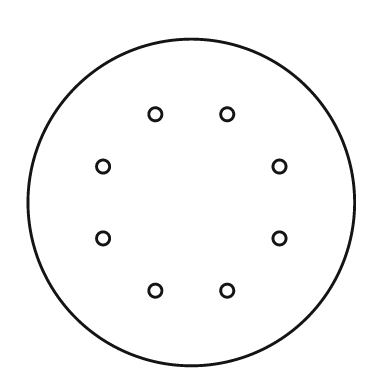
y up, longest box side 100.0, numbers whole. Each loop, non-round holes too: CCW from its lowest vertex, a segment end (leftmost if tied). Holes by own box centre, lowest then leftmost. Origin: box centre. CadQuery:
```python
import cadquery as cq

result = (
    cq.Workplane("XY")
    .moveTo(0.0, 0.0)
    .circle(50.0)
    .moveTo(-11.0, -27.0)
    .circle(2.0)
    .moveTo(11.0, -27.0)
    .circle(2.0)
    .moveTo(-27.0, -11.0)
    .circle(2.0)
    .moveTo(27.0, -11.0)
    .circle(2.0)
    .moveTo(-27.0, 11.0)
    .circle(2.0)
    .moveTo(27.0, 11.0)
    .circle(2.0)
    .moveTo(-11.0, 27.0)
    .circle(2.0)
    .moveTo(11.0, 27.0)
    .circle(2.0)
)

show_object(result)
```